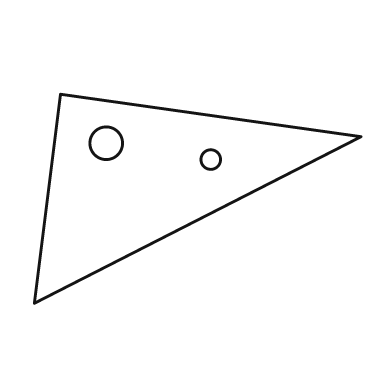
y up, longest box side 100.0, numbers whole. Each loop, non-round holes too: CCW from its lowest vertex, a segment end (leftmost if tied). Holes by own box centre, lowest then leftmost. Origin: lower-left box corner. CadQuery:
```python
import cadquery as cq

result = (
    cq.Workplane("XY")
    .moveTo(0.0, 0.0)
    .lineTo(100.0, 51.0)
    .lineTo(8.0, 64.0)
    .close()
    .moveTo(54.0, 44.0)
    .circle(3.0)
    .moveTo(22.0, 49.0)
    .circle(5.0)
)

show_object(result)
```